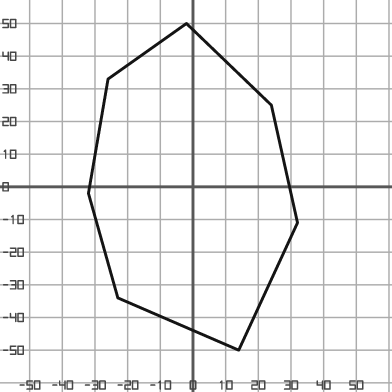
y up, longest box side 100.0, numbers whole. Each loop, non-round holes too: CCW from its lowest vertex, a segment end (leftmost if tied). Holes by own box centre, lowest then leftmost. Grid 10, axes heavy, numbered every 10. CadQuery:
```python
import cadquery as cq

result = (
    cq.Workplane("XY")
    .moveTo(14.0, -50.0)
    .lineTo(32.0, -11.0)
    .lineTo(24.0, 25.0)
    .lineTo(-2.0, 50.0)
    .lineTo(-26.0, 33.0)
    .lineTo(-32.0, -2.0)
    .lineTo(-23.0, -34.0)
    .close()
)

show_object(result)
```